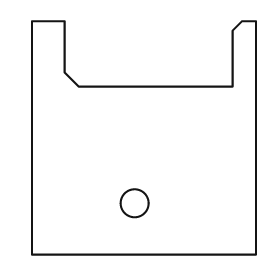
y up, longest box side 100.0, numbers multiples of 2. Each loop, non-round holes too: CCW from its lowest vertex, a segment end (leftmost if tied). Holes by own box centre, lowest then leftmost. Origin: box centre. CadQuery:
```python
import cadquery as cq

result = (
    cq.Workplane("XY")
    .moveTo(-48.0, -50.0)
    .lineTo(48.0, -50.0)
    .lineTo(48.0, 50.0)
    .lineTo(42.0, 50.0)
    .lineTo(38.0, 46.0)
    .lineTo(38.0, 22.0)
    .lineTo(-28.0, 22.0)
    .lineTo(-34.0, 28.0)
    .lineTo(-34.0, 50.0)
    .lineTo(-48.0, 50.0)
    .close()
    .moveTo(-4.0, -28.0)
    .circle(6.0)
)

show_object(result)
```